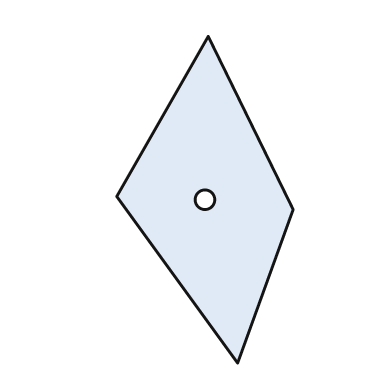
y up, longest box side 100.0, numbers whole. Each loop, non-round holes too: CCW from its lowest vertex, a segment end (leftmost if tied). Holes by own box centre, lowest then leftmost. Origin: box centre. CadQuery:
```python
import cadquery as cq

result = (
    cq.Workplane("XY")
    .moveTo(10.0, -50.0)
    .lineTo(27.0, -3.0)
    .lineTo(1.0, 50.0)
    .lineTo(-27.0, 1.0)
    .close()
    .moveTo(0.0, 0.0)
    .circle(3.0)
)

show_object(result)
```